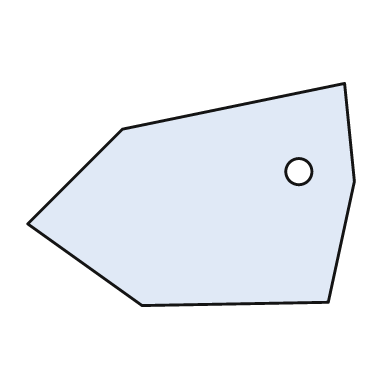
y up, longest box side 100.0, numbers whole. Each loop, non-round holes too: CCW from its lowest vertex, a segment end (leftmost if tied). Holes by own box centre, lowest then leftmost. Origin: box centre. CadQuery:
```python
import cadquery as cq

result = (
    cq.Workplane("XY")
    .moveTo(-15.0, -34.0)
    .lineTo(42.0, -33.0)
    .lineTo(50.0, 4.0)
    .lineTo(47.0, 34.0)
    .lineTo(-21.0, 20.0)
    .lineTo(-50.0, -9.0)
    .close()
    .moveTo(33.0, 7.0)
    .circle(4.0)
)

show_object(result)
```